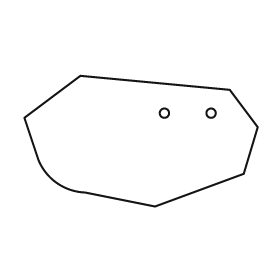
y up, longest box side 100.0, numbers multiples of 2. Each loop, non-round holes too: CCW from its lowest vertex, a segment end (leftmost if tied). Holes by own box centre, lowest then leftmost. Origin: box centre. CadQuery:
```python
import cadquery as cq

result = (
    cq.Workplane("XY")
    .moveTo(6.0, -28.0)
    .lineTo(44.0, -14.0)
    .lineTo(50.0, 6.0)
    .lineTo(38.0, 22.0)
    .lineTo(-26.0, 28.0)
    .lineTo(-50.0, 10.0)
    .lineTo(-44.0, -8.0)
    .threePointArc((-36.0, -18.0), (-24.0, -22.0))
    .close()
    .moveTo(10.0, 12.0)
    .circle(2.0)
    .moveTo(30.0, 12.0)
    .circle(2.0)
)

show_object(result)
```